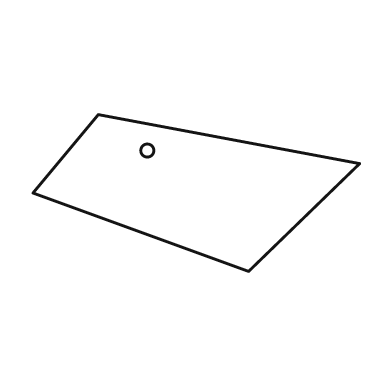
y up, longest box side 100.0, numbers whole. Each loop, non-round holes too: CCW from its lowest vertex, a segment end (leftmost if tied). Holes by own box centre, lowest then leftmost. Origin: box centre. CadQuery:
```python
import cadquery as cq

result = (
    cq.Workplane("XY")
    .moveTo(16.0, -24.0)
    .lineTo(50.0, 9.0)
    .lineTo(-30.0, 24.0)
    .lineTo(-50.0, 0.0)
    .close()
    .moveTo(-15.0, 13.0)
    .circle(2.0)
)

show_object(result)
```